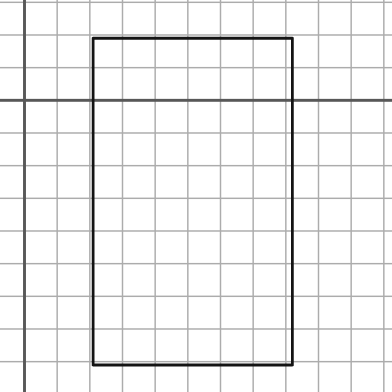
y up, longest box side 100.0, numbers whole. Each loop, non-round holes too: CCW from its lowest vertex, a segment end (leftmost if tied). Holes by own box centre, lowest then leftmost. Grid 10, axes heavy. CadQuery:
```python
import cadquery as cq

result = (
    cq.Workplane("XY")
    .moveTo(21.0, -81.0)
    .lineTo(82.0, -81.0)
    .lineTo(82.0, 19.0)
    .lineTo(21.0, 19.0)
    .close()
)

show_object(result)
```